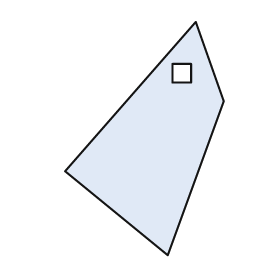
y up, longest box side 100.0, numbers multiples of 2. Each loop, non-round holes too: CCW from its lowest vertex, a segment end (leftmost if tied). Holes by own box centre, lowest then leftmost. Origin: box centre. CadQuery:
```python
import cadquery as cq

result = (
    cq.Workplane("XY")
    .moveTo(10.0, -50.0)
    .lineTo(34.0, 16.0)
    .lineTo(22.0, 50.0)
    .lineTo(-34.0, -14.0)
    .close()
    .moveTo(12.0, 24.0)
    .lineTo(20.0, 24.0)
    .lineTo(20.0, 32.0)
    .lineTo(12.0, 32.0)
    .close()
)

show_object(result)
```